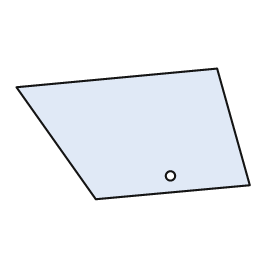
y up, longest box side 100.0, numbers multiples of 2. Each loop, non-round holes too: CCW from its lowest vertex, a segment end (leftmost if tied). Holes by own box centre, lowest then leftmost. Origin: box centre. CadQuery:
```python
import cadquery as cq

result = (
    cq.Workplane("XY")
    .moveTo(-16.0, -28.0)
    .lineTo(50.0, -22.0)
    .lineTo(36.0, 28.0)
    .lineTo(-50.0, 20.0)
    .close()
    .moveTo(16.0, -18.0)
    .circle(2.0)
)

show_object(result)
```